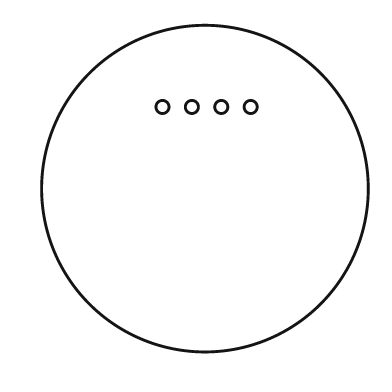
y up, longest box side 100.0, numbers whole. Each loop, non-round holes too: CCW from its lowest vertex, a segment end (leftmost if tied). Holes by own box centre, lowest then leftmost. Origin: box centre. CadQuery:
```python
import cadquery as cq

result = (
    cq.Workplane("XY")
    .moveTo(0.0, 0.0)
    .circle(50.0)
    .moveTo(-13.0, 25.0)
    .circle(2.0)
    .moveTo(-4.0, 25.0)
    .circle(2.0)
    .moveTo(5.0, 25.0)
    .circle(2.0)
    .moveTo(14.0, 25.0)
    .circle(2.0)
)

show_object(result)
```